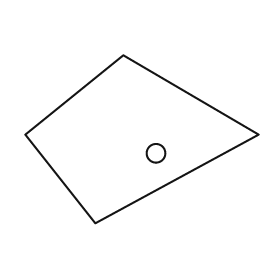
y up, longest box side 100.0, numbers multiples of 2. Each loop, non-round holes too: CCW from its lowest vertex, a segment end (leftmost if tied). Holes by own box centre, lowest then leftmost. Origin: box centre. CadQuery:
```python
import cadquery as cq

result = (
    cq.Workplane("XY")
    .moveTo(-20.0, -36.0)
    .lineTo(50.0, 2.0)
    .lineTo(-8.0, 36.0)
    .lineTo(-50.0, 2.0)
    .close()
    .moveTo(6.0, -6.0)
    .circle(4.0)
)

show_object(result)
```